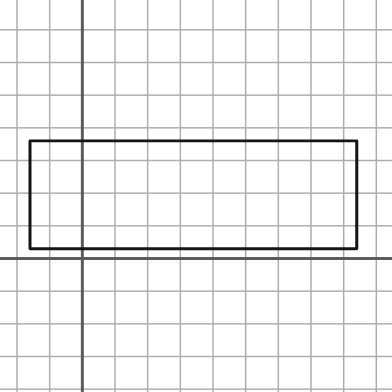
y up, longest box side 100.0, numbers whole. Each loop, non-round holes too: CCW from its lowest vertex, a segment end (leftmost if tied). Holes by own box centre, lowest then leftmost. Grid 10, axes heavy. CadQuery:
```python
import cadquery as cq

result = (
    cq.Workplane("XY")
    .moveTo(-16.0, 3.0)
    .lineTo(84.0, 3.0)
    .lineTo(84.0, 36.0)
    .lineTo(-16.0, 36.0)
    .close()
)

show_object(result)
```